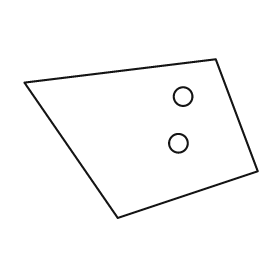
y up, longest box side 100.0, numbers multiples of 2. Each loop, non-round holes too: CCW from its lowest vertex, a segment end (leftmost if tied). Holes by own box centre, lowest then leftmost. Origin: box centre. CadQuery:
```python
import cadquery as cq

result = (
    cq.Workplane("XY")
    .moveTo(-10.0, -34.0)
    .lineTo(50.0, -14.0)
    .lineTo(32.0, 34.0)
    .lineTo(-50.0, 24.0)
    .close()
    .moveTo(16.0, -2.0)
    .circle(4.0)
    .moveTo(18.0, 18.0)
    .circle(4.0)
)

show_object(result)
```